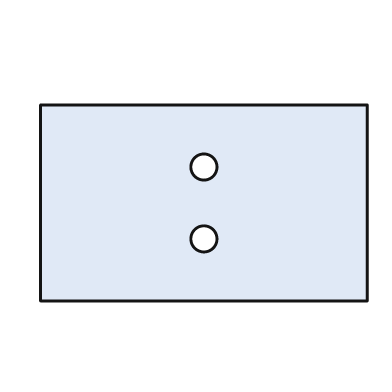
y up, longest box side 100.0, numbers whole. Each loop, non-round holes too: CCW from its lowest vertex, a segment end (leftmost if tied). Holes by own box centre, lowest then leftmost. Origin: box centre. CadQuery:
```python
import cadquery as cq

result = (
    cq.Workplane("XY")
    .moveTo(-50.0, -30.0)
    .lineTo(50.0, -30.0)
    .lineTo(50.0, 30.0)
    .lineTo(-50.0, 30.0)
    .close()
    .moveTo(0.0, -11.0)
    .circle(4.0)
    .moveTo(0.0, 11.0)
    .circle(4.0)
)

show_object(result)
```